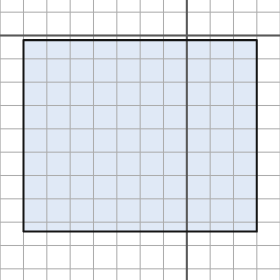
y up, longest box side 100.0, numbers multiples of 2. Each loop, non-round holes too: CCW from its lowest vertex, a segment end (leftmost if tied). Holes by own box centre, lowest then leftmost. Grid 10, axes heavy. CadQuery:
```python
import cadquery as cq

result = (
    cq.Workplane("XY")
    .moveTo(-70.0, -84.0)
    .lineTo(30.0, -84.0)
    .lineTo(30.0, -2.0)
    .lineTo(-70.0, -2.0)
    .close()
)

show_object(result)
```